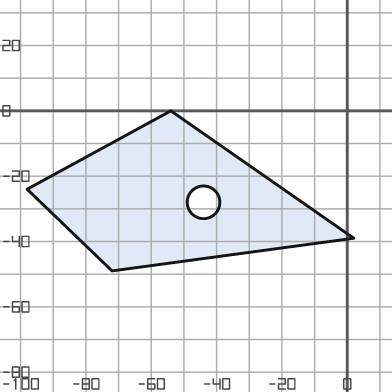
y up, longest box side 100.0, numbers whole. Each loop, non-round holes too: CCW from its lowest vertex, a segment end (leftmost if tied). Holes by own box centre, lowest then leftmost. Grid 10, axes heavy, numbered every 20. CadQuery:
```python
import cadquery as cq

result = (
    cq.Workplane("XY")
    .moveTo(-72.0, -49.0)
    .lineTo(2.0, -39.0)
    .lineTo(-54.0, 0.0)
    .lineTo(-98.0, -24.0)
    .close()
    .moveTo(-44.0, -28.0)
    .circle(5.0)
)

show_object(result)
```